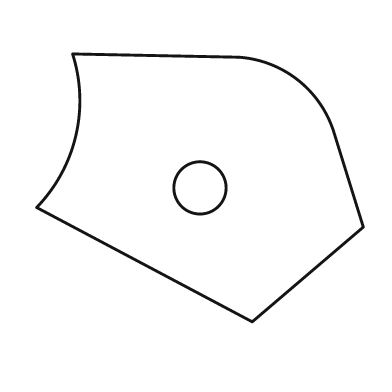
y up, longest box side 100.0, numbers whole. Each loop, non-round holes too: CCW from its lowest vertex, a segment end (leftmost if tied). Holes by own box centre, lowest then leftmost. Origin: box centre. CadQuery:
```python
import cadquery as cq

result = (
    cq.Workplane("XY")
    .moveTo(16.0, -41.0)
    .lineTo(50.0, -12.0)
    .lineTo(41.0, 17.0)
    .threePointArc((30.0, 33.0), (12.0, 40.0))
    .lineTo(-39.0, 41.0)
    .threePointArc((-38.0, 16.0), (-50.0, -6.0))
    .close()
    .moveTo(0.0, 0.0)
    .circle(8.0)
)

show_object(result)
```